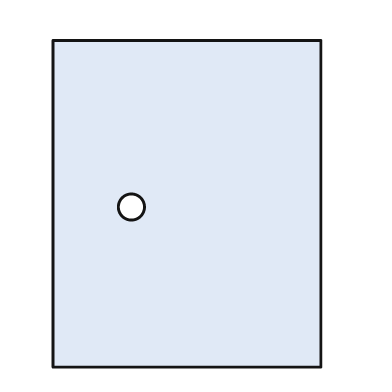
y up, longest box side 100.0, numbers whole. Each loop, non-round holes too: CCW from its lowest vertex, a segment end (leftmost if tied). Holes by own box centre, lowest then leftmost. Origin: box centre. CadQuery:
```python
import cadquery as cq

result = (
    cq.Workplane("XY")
    .moveTo(-41.0, -50.0)
    .lineTo(41.0, -50.0)
    .lineTo(41.0, 50.0)
    .lineTo(-41.0, 50.0)
    .close()
    .moveTo(-17.0, -1.0)
    .circle(4.0)
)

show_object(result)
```